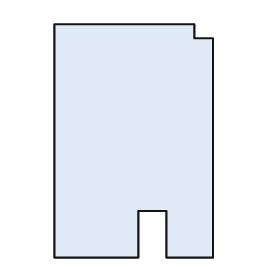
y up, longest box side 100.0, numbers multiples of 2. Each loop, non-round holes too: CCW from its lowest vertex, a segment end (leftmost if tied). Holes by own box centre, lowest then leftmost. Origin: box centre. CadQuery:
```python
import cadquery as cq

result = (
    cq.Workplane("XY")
    .moveTo(-34.0, -50.0)
    .lineTo(2.0, -50.0)
    .lineTo(2.0, -30.0)
    .lineTo(14.0, -30.0)
    .lineTo(14.0, -50.0)
    .lineTo(34.0, -50.0)
    .lineTo(34.0, 44.0)
    .lineTo(26.0, 44.0)
    .lineTo(26.0, 50.0)
    .lineTo(-34.0, 50.0)
    .close()
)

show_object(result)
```